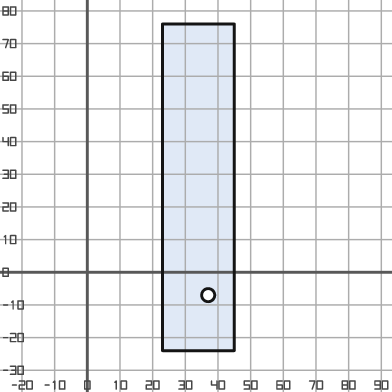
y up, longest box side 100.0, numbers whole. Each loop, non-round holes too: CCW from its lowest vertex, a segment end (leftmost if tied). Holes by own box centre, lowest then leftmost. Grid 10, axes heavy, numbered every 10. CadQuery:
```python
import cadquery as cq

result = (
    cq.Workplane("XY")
    .moveTo(23.0, -24.0)
    .lineTo(45.0, -24.0)
    .lineTo(45.0, 76.0)
    .lineTo(23.0, 76.0)
    .close()
    .moveTo(37.0, -7.0)
    .circle(2.0)
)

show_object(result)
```